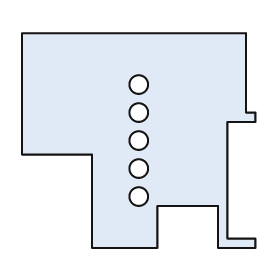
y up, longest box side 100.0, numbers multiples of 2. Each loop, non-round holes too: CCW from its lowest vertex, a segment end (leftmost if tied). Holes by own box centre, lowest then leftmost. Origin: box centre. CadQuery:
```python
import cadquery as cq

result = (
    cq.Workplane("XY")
    .moveTo(-20.0, -46.0)
    .lineTo(8.0, -46.0)
    .lineTo(8.0, -28.0)
    .lineTo(34.0, -28.0)
    .lineTo(34.0, -46.0)
    .lineTo(50.0, -46.0)
    .lineTo(50.0, -42.0)
    .lineTo(38.0, -42.0)
    .lineTo(38.0, 8.0)
    .lineTo(50.0, 8.0)
    .lineTo(50.0, 12.0)
    .lineTo(46.0, 12.0)
    .lineTo(46.0, 46.0)
    .lineTo(-50.0, 46.0)
    .lineTo(-50.0, -6.0)
    .lineTo(-20.0, -6.0)
    .close()
    .moveTo(0.0, -24.0)
    .circle(4.0)
    .moveTo(0.0, -12.0)
    .circle(4.0)
    .moveTo(0.0, 0.0)
    .circle(4.0)
    .moveTo(0.0, 12.0)
    .circle(4.0)
    .moveTo(0.0, 24.0)
    .circle(4.0)
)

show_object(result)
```